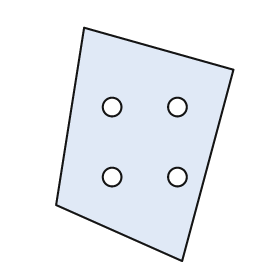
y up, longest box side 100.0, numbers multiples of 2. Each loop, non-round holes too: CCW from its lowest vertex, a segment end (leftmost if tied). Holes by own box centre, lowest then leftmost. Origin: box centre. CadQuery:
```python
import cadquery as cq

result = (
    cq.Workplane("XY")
    .moveTo(16.0, -50.0)
    .lineTo(38.0, 32.0)
    .lineTo(-26.0, 50.0)
    .lineTo(-38.0, -26.0)
    .close()
    .moveTo(-14.0, -14.0)
    .circle(4.0)
    .moveTo(14.0, -14.0)
    .circle(4.0)
    .moveTo(-14.0, 16.0)
    .circle(4.0)
    .moveTo(14.0, 16.0)
    .circle(4.0)
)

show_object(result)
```